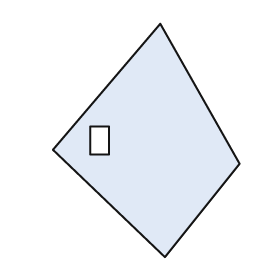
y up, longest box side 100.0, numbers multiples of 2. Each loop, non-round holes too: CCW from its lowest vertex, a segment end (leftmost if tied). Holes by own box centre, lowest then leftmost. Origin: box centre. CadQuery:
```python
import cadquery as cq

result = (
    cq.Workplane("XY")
    .moveTo(8.0, -50.0)
    .lineTo(40.0, -10.0)
    .lineTo(6.0, 50.0)
    .lineTo(-40.0, -4.0)
    .close()
    .moveTo(-24.0, -6.0)
    .lineTo(-16.0, -6.0)
    .lineTo(-16.0, 6.0)
    .lineTo(-24.0, 6.0)
    .close()
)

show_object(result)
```